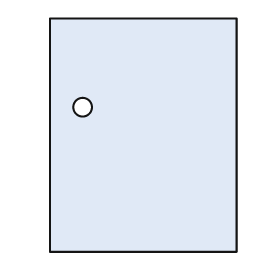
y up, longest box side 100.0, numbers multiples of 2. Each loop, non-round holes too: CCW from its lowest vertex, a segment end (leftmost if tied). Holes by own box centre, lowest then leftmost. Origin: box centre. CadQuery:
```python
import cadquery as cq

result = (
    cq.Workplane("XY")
    .moveTo(-40.0, -50.0)
    .lineTo(40.0, -50.0)
    .lineTo(40.0, 50.0)
    .lineTo(-40.0, 50.0)
    .close()
    .moveTo(-26.0, 12.0)
    .circle(4.0)
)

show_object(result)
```